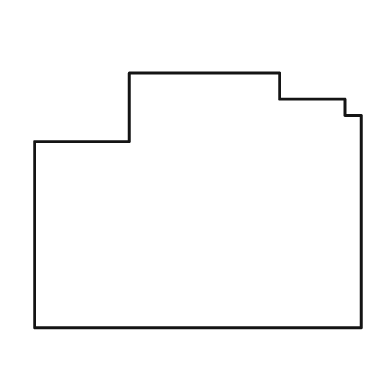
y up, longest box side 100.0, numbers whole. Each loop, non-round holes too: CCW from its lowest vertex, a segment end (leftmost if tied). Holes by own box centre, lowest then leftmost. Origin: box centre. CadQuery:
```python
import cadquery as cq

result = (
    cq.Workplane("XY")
    .moveTo(-50.0, -39.0)
    .lineTo(50.0, -39.0)
    .lineTo(50.0, 26.0)
    .lineTo(45.0, 26.0)
    .lineTo(45.0, 31.0)
    .lineTo(25.0, 31.0)
    .lineTo(25.0, 39.0)
    .lineTo(-21.0, 39.0)
    .lineTo(-21.0, 18.0)
    .lineTo(-50.0, 18.0)
    .close()
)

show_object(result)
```